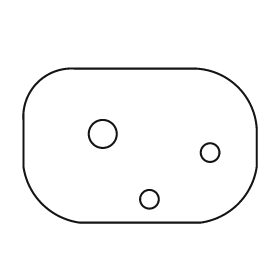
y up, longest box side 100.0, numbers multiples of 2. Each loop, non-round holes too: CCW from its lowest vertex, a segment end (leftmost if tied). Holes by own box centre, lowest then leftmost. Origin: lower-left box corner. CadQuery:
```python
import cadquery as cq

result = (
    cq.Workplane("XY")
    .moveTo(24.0, 0.0)
    .lineTo(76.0, 0.0)
    .threePointArc((92.0, 8.0), (100.0, 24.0))
    .lineTo(100.0, 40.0)
    .threePointArc((92.0, 58.0), (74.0, 66.0))
    .lineTo(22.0, 66.0)
    .threePointArc((6.0, 60.0), (0.0, 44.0))
    .lineTo(0.0, 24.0)
    .threePointArc((8.0, 8.0), (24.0, 0.0))
    .close()
    .moveTo(54.0, 10.0)
    .circle(4.0)
    .moveTo(80.0, 30.0)
    .circle(4.0)
    .moveTo(34.0, 38.0)
    .circle(6.0)
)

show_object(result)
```